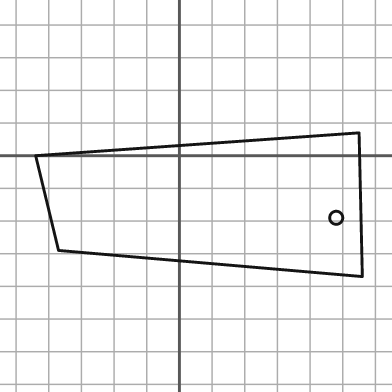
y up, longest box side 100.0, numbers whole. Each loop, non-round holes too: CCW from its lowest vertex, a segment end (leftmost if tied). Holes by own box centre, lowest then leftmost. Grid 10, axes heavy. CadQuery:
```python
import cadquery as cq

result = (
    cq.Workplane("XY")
    .moveTo(56.0, -37.0)
    .lineTo(55.0, 7.0)
    .lineTo(-44.0, 0.0)
    .lineTo(-37.0, -29.0)
    .close()
    .moveTo(48.0, -19.0)
    .circle(2.0)
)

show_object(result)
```